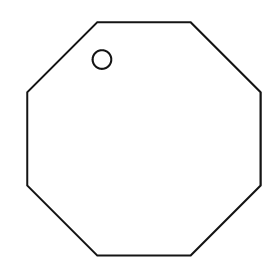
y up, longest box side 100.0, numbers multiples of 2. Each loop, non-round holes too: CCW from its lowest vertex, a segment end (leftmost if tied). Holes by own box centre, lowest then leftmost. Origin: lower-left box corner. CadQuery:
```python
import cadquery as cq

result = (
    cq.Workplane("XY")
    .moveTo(30.0, 0.0)
    .lineTo(70.0, 0.0)
    .lineTo(100.0, 30.0)
    .lineTo(100.0, 70.0)
    .lineTo(70.0, 100.0)
    .lineTo(30.0, 100.0)
    .lineTo(0.0, 70.0)
    .lineTo(0.0, 30.0)
    .close()
    .moveTo(32.0, 84.0)
    .circle(4.0)
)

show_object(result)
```